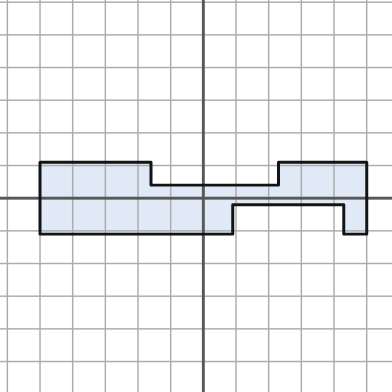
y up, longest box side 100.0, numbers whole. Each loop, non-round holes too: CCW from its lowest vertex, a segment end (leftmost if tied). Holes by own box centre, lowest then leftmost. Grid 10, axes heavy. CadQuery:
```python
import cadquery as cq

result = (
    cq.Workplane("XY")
    .moveTo(-50.0, -11.0)
    .lineTo(9.0, -11.0)
    .lineTo(9.0, -2.0)
    .lineTo(43.0, -2.0)
    .lineTo(43.0, -11.0)
    .lineTo(50.0, -11.0)
    .lineTo(50.0, 11.0)
    .lineTo(23.0, 11.0)
    .lineTo(23.0, 4.0)
    .lineTo(-16.0, 4.0)
    .lineTo(-16.0, 11.0)
    .lineTo(-50.0, 11.0)
    .close()
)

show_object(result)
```